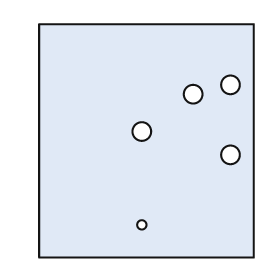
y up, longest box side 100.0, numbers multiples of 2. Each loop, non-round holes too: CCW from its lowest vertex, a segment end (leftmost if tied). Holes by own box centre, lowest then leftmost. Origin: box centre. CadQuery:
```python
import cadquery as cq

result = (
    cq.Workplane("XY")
    .moveTo(-46.0, -50.0)
    .lineTo(46.0, -50.0)
    .lineTo(46.0, 50.0)
    .lineTo(-46.0, 50.0)
    .close()
    .moveTo(-2.0, -36.0)
    .circle(2.0)
    .moveTo(36.0, -6.0)
    .circle(4.0)
    .moveTo(-2.0, 4.0)
    .circle(4.0)
    .moveTo(20.0, 20.0)
    .circle(4.0)
    .moveTo(36.0, 24.0)
    .circle(4.0)
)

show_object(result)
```